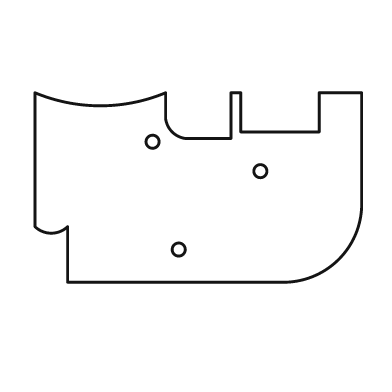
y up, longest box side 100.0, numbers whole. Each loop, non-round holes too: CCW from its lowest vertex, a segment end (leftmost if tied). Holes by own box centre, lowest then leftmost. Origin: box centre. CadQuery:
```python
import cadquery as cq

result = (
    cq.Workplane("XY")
    .moveTo(-40.0, -29.0)
    .lineTo(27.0, -29.0)
    .threePointArc((43.0, -22.0), (50.0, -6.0))
    .lineTo(50.0, 29.0)
    .lineTo(37.0, 29.0)
    .lineTo(37.0, 17.0)
    .lineTo(13.0, 17.0)
    .lineTo(13.0, 29.0)
    .lineTo(10.0, 29.0)
    .lineTo(10.0, 15.0)
    .lineTo(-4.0, 15.0)
    .threePointArc((-8.0, 17.0), (-10.0, 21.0))
    .lineTo(-10.0, 29.0)
    .threePointArc((-30.0, 25.0), (-50.0, 29.0))
    .lineTo(-50.0, -12.0)
    .threePointArc((-45.0, -14.0), (-40.0, -12.0))
    .close()
    .moveTo(-6.0, -19.0)
    .circle(2.0)
    .moveTo(19.0, 5.0)
    .circle(2.0)
    .moveTo(-14.0, 14.0)
    .circle(2.0)
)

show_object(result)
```